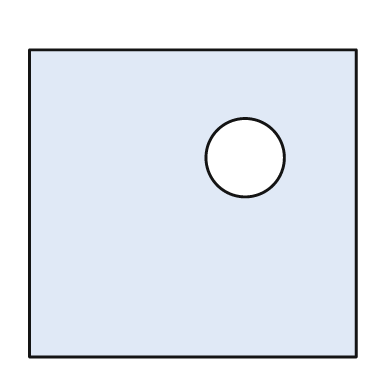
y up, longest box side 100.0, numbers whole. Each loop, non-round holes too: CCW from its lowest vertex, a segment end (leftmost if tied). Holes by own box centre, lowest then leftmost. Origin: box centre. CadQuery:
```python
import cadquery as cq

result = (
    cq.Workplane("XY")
    .moveTo(-50.0, -47.0)
    .lineTo(50.0, -47.0)
    .lineTo(50.0, 47.0)
    .lineTo(-50.0, 47.0)
    .close()
    .moveTo(16.0, 14.0)
    .circle(12.0)
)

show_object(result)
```